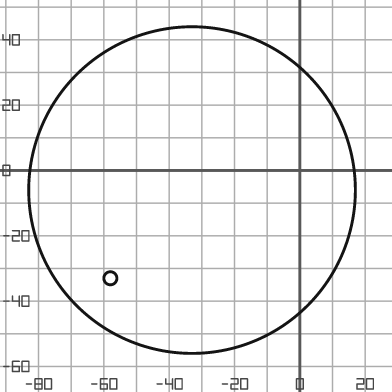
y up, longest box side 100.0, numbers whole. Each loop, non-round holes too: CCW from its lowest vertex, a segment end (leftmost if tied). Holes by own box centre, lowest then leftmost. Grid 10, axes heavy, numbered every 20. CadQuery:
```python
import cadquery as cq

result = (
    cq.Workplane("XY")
    .moveTo(-33.0, -6.0)
    .circle(50.0)
    .moveTo(-58.0, -33.0)
    .circle(2.0)
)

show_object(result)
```